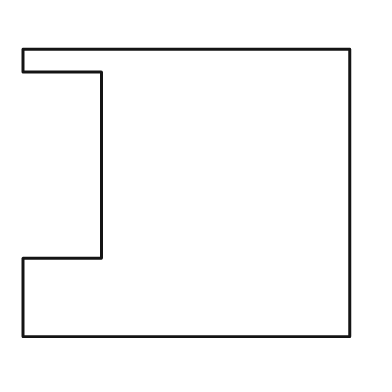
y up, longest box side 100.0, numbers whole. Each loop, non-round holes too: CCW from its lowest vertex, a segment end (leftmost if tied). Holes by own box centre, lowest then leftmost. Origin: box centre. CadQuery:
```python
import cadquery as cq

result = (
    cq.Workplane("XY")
    .moveTo(-50.0, -44.0)
    .lineTo(50.0, -44.0)
    .lineTo(50.0, 44.0)
    .lineTo(-50.0, 44.0)
    .lineTo(-50.0, 37.0)
    .lineTo(-26.0, 37.0)
    .lineTo(-26.0, -20.0)
    .lineTo(-50.0, -20.0)
    .close()
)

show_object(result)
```